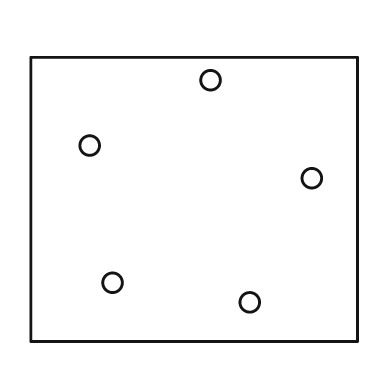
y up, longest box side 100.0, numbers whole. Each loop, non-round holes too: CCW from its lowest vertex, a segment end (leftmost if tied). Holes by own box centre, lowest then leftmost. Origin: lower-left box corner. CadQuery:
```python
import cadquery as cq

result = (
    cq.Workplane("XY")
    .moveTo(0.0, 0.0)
    .lineTo(100.0, 0.0)
    .lineTo(100.0, 87.0)
    .lineTo(0.0, 87.0)
    .close()
    .moveTo(67.0, 12.0)
    .circle(3.0)
    .moveTo(25.0, 18.0)
    .circle(3.0)
    .moveTo(86.0, 50.0)
    .circle(3.0)
    .moveTo(18.0, 60.0)
    .circle(3.0)
    .moveTo(55.0, 80.0)
    .circle(3.0)
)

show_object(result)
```